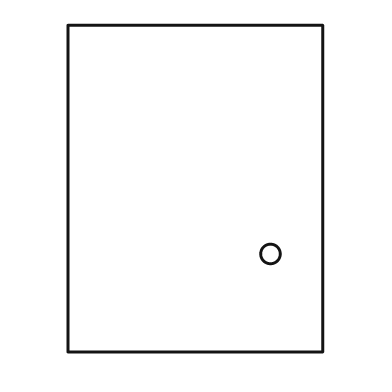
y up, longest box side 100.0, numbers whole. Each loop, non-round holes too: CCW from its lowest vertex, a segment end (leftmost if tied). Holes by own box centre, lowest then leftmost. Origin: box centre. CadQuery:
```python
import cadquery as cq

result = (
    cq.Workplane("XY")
    .moveTo(-39.0, -50.0)
    .lineTo(39.0, -50.0)
    .lineTo(39.0, 50.0)
    .lineTo(-39.0, 50.0)
    .close()
    .moveTo(23.0, -20.0)
    .circle(3.0)
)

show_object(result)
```